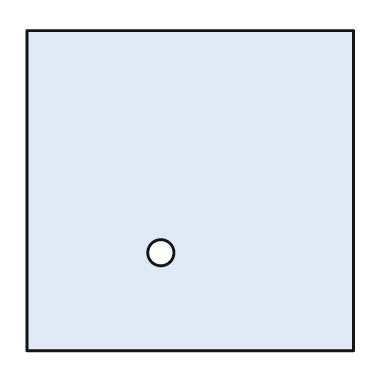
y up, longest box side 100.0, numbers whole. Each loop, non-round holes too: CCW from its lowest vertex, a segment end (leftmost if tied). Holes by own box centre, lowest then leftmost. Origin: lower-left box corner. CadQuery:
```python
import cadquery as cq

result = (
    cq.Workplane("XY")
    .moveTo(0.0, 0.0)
    .lineTo(100.0, 0.0)
    .lineTo(100.0, 98.0)
    .lineTo(0.0, 98.0)
    .close()
    .moveTo(41.0, 30.0)
    .circle(4.0)
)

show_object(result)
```